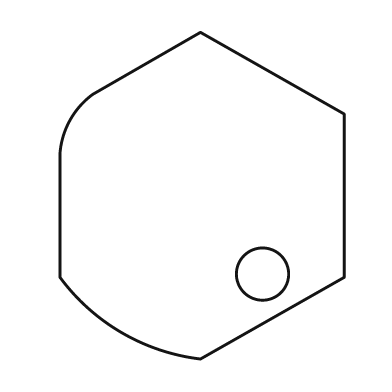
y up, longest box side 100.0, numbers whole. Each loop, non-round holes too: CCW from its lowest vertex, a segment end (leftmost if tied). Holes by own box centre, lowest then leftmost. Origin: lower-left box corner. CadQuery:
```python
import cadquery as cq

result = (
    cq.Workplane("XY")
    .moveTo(43.0, 0.0)
    .lineTo(87.0, 25.0)
    .lineTo(87.0, 75.0)
    .lineTo(43.0, 100.0)
    .lineTo(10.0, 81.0)
    .threePointArc((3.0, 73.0), (0.0, 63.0))
    .lineTo(0.0, 25.0)
    .threePointArc((19.0, 8.0), (43.0, 0.0))
    .close()
    .moveTo(62.0, 26.0)
    .circle(8.0)
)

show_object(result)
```